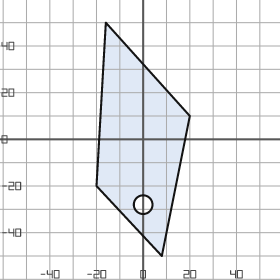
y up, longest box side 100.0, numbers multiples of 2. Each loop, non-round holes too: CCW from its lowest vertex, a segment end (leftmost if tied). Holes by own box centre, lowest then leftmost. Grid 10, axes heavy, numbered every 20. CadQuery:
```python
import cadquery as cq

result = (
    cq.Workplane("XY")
    .moveTo(8.0, -50.0)
    .lineTo(20.0, 10.0)
    .lineTo(-16.0, 50.0)
    .lineTo(-20.0, -20.0)
    .close()
    .moveTo(0.0, -28.0)
    .circle(4.0)
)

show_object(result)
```